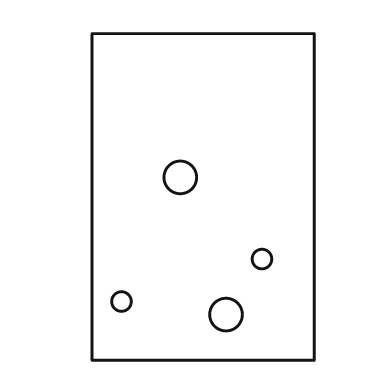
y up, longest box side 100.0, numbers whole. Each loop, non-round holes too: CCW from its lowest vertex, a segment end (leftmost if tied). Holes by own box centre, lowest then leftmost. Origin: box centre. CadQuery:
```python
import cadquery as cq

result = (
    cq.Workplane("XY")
    .moveTo(-34.0, -50.0)
    .lineTo(34.0, -50.0)
    .lineTo(34.0, 50.0)
    .lineTo(-34.0, 50.0)
    .close()
    .moveTo(7.0, -36.0)
    .circle(5.0)
    .moveTo(-25.0, -32.0)
    .circle(3.0)
    .moveTo(18.0, -19.0)
    .circle(3.0)
    .moveTo(-7.0, 6.0)
    .circle(5.0)
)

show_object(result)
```